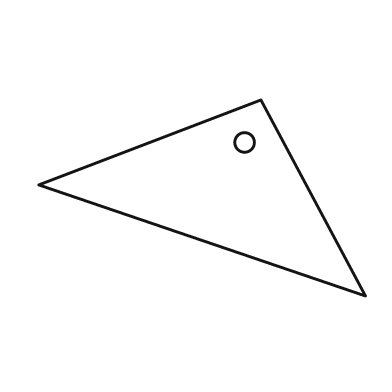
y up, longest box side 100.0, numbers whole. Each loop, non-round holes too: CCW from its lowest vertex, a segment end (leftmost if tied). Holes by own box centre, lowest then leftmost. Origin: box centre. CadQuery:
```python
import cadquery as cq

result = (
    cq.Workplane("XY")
    .moveTo(50.0, -30.0)
    .lineTo(18.0, 30.0)
    .lineTo(-50.0, 4.0)
    .close()
    .moveTo(13.0, 17.0)
    .circle(3.0)
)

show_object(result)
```